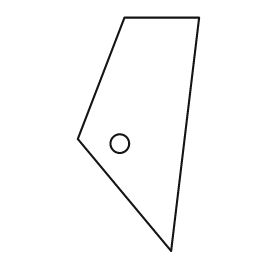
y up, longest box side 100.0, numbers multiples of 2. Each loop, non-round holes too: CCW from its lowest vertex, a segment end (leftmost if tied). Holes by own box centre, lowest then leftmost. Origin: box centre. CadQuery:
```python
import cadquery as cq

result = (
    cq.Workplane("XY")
    .moveTo(14.0, -50.0)
    .lineTo(26.0, 50.0)
    .lineTo(-6.0, 50.0)
    .lineTo(-26.0, -2.0)
    .close()
    .moveTo(-8.0, -4.0)
    .circle(4.0)
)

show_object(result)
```